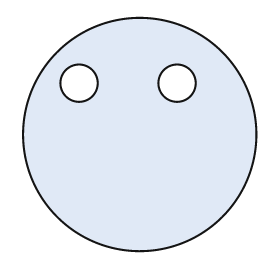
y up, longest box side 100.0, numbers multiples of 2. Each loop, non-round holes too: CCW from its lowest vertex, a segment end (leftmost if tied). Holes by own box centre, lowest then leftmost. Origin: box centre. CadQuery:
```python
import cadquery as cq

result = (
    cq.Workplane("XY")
    .moveTo(0.0, 0.0)
    .circle(50.0)
    .moveTo(-26.0, 22.0)
    .circle(8.0)
    .moveTo(16.0, 22.0)
    .circle(8.0)
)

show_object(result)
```